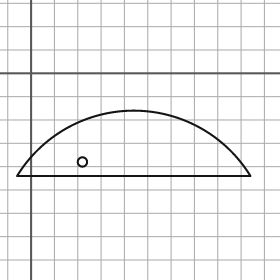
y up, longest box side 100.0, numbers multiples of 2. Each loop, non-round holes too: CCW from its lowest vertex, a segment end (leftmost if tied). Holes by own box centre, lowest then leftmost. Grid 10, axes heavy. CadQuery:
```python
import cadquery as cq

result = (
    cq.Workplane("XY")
    .moveTo(-6.0, -44.0)
    .lineTo(94.0, -44.0)
    .threePointArc((44.0, -16.0), (-6.0, -44.0))
    .close()
    .moveTo(22.0, -38.0)
    .circle(2.0)
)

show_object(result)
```